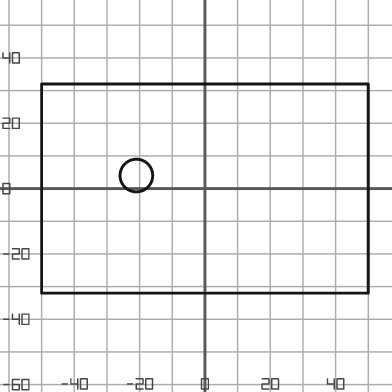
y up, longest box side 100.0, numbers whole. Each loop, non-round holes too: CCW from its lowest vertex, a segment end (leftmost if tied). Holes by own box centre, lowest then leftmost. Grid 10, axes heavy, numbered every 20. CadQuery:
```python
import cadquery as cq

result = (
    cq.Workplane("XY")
    .moveTo(-50.0, -32.0)
    .lineTo(50.0, -32.0)
    .lineTo(50.0, 32.0)
    .lineTo(-50.0, 32.0)
    .close()
    .moveTo(-21.0, 4.0)
    .circle(5.0)
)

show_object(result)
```